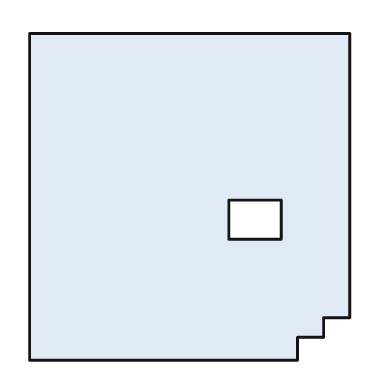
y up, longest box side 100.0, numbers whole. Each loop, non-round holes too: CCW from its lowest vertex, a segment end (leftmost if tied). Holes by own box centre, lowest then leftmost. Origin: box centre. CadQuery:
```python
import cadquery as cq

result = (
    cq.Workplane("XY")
    .moveTo(-49.0, -50.0)
    .lineTo(33.0, -50.0)
    .lineTo(33.0, -43.0)
    .lineTo(41.0, -43.0)
    .lineTo(41.0, -37.0)
    .lineTo(49.0, -37.0)
    .lineTo(49.0, 50.0)
    .lineTo(-49.0, 50.0)
    .close()
    .moveTo(12.0, -13.0)
    .lineTo(28.0, -13.0)
    .lineTo(28.0, -1.0)
    .lineTo(12.0, -1.0)
    .close()
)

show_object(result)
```